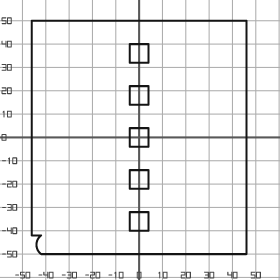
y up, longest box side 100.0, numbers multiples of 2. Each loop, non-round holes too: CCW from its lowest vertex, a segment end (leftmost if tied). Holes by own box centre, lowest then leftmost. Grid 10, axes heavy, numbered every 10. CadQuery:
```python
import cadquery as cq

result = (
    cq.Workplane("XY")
    .moveTo(-42.0, -50.0)
    .lineTo(46.0, -50.0)
    .lineTo(46.0, 50.0)
    .lineTo(-46.0, 50.0)
    .lineTo(-46.0, -42.0)
    .lineTo(-42.0, -42.0)
    .threePointArc((-44.0, -46.0), (-42.0, -50.0))
    .close()
    .moveTo(-4.0, -40.0)
    .lineTo(4.0, -40.0)
    .lineTo(4.0, -32.0)
    .lineTo(-4.0, -32.0)
    .close()
    .moveTo(-4.0, -22.0)
    .lineTo(4.0, -22.0)
    .lineTo(4.0, -14.0)
    .lineTo(-4.0, -14.0)
    .close()
    .moveTo(-4.0, -4.0)
    .lineTo(4.0, -4.0)
    .lineTo(4.0, 4.0)
    .lineTo(-4.0, 4.0)
    .close()
    .moveTo(-4.0, 14.0)
    .lineTo(4.0, 14.0)
    .lineTo(4.0, 22.0)
    .lineTo(-4.0, 22.0)
    .close()
    .moveTo(-4.0, 32.0)
    .lineTo(4.0, 32.0)
    .lineTo(4.0, 40.0)
    .lineTo(-4.0, 40.0)
    .close()
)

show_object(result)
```